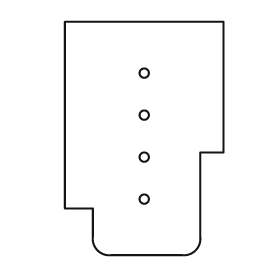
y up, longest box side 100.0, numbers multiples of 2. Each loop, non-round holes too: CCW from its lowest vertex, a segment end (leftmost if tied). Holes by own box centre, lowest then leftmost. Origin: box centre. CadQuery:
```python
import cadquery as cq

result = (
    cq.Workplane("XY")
    .moveTo(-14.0, -50.0)
    .lineTo(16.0, -50.0)
    .threePointArc((22.0, -48.0), (24.0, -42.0))
    .lineTo(24.0, -6.0)
    .lineTo(34.0, -6.0)
    .lineTo(34.0, 50.0)
    .lineTo(-34.0, 50.0)
    .lineTo(-34.0, -30.0)
    .lineTo(-22.0, -30.0)
    .lineTo(-22.0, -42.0)
    .threePointArc((-20.0, -48.0), (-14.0, -50.0))
    .close()
    .moveTo(0.0, -26.0)
    .circle(2.0)
    .moveTo(0.0, -8.0)
    .circle(2.0)
    .moveTo(0.0, 10.0)
    .circle(2.0)
    .moveTo(0.0, 28.0)
    .circle(2.0)
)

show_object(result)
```